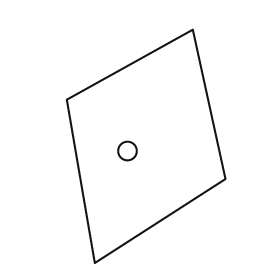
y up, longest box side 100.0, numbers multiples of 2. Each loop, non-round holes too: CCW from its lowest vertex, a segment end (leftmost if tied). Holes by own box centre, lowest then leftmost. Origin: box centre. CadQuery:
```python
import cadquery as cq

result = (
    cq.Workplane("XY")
    .moveTo(-22.0, -50.0)
    .lineTo(34.0, -14.0)
    .lineTo(20.0, 50.0)
    .lineTo(-34.0, 20.0)
    .close()
    .moveTo(-8.0, -2.0)
    .circle(4.0)
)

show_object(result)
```